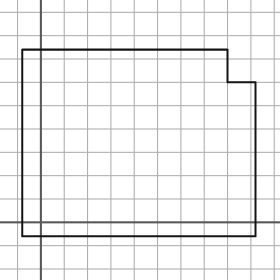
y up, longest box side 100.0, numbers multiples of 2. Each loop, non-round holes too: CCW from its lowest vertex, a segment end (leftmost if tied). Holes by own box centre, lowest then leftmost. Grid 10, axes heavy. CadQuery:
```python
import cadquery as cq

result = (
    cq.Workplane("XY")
    .moveTo(-8.0, -6.0)
    .lineTo(92.0, -6.0)
    .lineTo(92.0, 60.0)
    .lineTo(80.0, 60.0)
    .lineTo(80.0, 74.0)
    .lineTo(-8.0, 74.0)
    .close()
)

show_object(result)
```